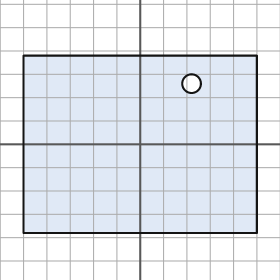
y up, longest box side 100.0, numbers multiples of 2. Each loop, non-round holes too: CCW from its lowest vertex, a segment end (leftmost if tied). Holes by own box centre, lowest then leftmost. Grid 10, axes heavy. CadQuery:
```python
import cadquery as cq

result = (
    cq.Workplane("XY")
    .moveTo(-50.0, -38.0)
    .lineTo(50.0, -38.0)
    .lineTo(50.0, 38.0)
    .lineTo(-50.0, 38.0)
    .close()
    .moveTo(22.0, 26.0)
    .circle(4.0)
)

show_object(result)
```